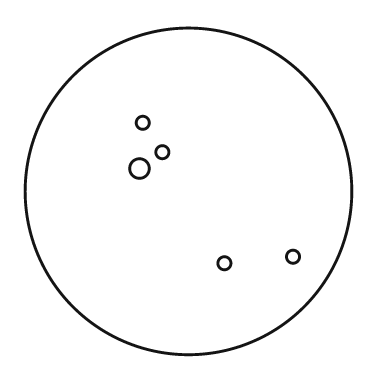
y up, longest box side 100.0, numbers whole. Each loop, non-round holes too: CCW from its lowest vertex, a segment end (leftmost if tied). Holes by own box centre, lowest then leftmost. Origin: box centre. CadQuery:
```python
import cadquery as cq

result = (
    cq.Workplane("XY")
    .moveTo(0.0, 0.0)
    .circle(50.0)
    .moveTo(11.0, -22.0)
    .circle(2.0)
    .moveTo(32.0, -20.0)
    .circle(2.0)
    .moveTo(-15.0, 7.0)
    .circle(3.0)
    .moveTo(-8.0, 12.0)
    .circle(2.0)
    .moveTo(-14.0, 21.0)
    .circle(2.0)
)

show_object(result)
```